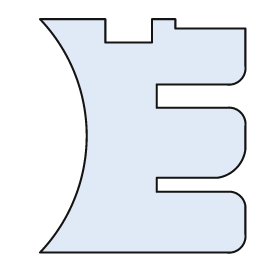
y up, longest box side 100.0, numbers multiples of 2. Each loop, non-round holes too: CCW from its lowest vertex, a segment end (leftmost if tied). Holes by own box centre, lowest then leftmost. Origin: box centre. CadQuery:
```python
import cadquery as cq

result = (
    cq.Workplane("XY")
    .moveTo(-44.0, -50.0)
    .lineTo(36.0, -50.0)
    .threePointArc((42.0, -48.0), (44.0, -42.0))
    .lineTo(44.0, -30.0)
    .threePointArc((42.0, -26.0), (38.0, -24.0))
    .lineTo(6.0, -24.0)
    .lineTo(6.0, -18.0)
    .lineTo(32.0, -18.0)
    .threePointArc((40.0, -14.0), (44.0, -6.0))
    .lineTo(44.0, 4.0)
    .threePointArc((42.0, 10.0), (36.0, 12.0))
    .lineTo(6.0, 12.0)
    .lineTo(6.0, 22.0)
    .lineTo(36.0, 22.0)
    .threePointArc((42.0, 24.0), (44.0, 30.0))
    .lineTo(44.0, 46.0)
    .lineTo(14.0, 46.0)
    .lineTo(14.0, 50.0)
    .lineTo(4.0, 50.0)
    .lineTo(4.0, 40.0)
    .lineTo(-16.0, 40.0)
    .lineTo(-16.0, 50.0)
    .lineTo(-44.0, 50.0)
    .threePointArc((-24.0, 0.0), (-44.0, -50.0))
    .close()
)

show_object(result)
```